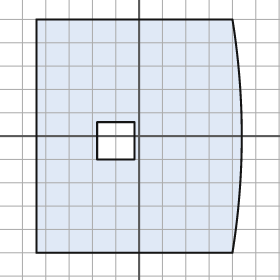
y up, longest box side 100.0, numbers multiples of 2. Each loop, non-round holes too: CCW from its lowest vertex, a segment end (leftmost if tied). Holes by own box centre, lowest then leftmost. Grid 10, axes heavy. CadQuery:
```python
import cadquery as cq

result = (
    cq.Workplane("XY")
    .moveTo(-44.0, -50.0)
    .lineTo(40.0, -50.0)
    .threePointArc((44.0, 0.0), (40.0, 50.0))
    .lineTo(-44.0, 50.0)
    .close()
    .moveTo(-18.0, -10.0)
    .lineTo(-2.0, -10.0)
    .lineTo(-2.0, 6.0)
    .lineTo(-18.0, 6.0)
    .close()
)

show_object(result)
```